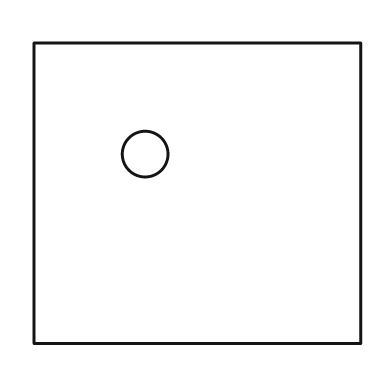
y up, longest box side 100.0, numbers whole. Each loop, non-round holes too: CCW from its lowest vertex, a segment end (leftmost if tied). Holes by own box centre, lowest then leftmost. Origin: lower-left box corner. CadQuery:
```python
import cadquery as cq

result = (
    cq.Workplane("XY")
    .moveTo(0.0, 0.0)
    .lineTo(100.0, 0.0)
    .lineTo(100.0, 92.0)
    .lineTo(0.0, 92.0)
    .close()
    .moveTo(34.0, 58.0)
    .circle(7.0)
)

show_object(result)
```